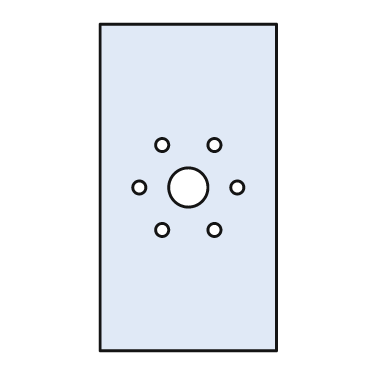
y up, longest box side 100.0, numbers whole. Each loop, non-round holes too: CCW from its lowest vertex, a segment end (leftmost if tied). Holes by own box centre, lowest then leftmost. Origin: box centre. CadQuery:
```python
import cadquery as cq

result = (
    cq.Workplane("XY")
    .moveTo(-27.0, -50.0)
    .lineTo(27.0, -50.0)
    .lineTo(27.0, 50.0)
    .lineTo(-27.0, 50.0)
    .close()
    .moveTo(-8.0, -13.0)
    .circle(2.0)
    .moveTo(8.0, -13.0)
    .circle(2.0)
    .moveTo(-15.0, 0.0)
    .circle(2.0)
    .moveTo(0.0, 0.0)
    .circle(6.0)
    .moveTo(15.0, 0.0)
    .circle(2.0)
    .moveTo(-8.0, 13.0)
    .circle(2.0)
    .moveTo(8.0, 13.0)
    .circle(2.0)
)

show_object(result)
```